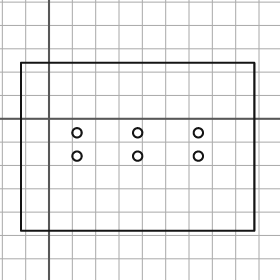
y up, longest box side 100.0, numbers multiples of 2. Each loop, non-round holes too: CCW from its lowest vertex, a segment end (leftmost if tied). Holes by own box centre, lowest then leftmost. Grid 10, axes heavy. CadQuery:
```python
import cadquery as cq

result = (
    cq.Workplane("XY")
    .moveTo(-12.0, -48.0)
    .lineTo(88.0, -48.0)
    .lineTo(88.0, 24.0)
    .lineTo(-12.0, 24.0)
    .close()
    .moveTo(12.0, -16.0)
    .circle(2.0)
    .moveTo(38.0, -16.0)
    .circle(2.0)
    .moveTo(64.0, -16.0)
    .circle(2.0)
    .moveTo(12.0, -6.0)
    .circle(2.0)
    .moveTo(38.0, -6.0)
    .circle(2.0)
    .moveTo(64.0, -6.0)
    .circle(2.0)
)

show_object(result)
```